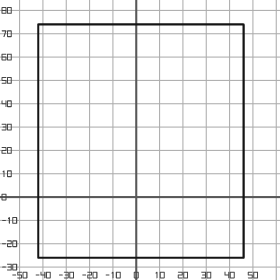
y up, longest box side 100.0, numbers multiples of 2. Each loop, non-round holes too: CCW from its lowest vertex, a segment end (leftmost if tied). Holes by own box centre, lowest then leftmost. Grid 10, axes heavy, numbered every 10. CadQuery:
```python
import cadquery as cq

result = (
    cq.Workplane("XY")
    .moveTo(-42.0, -26.0)
    .lineTo(46.0, -26.0)
    .lineTo(46.0, 74.0)
    .lineTo(-42.0, 74.0)
    .close()
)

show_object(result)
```